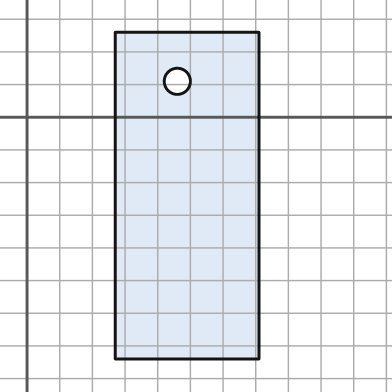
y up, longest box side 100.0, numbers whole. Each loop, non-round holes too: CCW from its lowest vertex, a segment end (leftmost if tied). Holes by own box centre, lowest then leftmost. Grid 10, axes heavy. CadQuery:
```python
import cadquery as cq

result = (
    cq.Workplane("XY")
    .moveTo(27.0, -74.0)
    .lineTo(71.0, -74.0)
    .lineTo(71.0, 26.0)
    .lineTo(27.0, 26.0)
    .close()
    .moveTo(46.0, 11.0)
    .circle(4.0)
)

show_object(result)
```